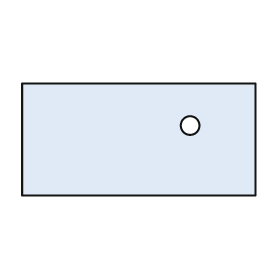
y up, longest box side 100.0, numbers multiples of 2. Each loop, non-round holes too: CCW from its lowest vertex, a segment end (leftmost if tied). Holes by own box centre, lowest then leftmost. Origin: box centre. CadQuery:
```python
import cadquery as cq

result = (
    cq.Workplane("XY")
    .moveTo(-50.0, -24.0)
    .lineTo(50.0, -24.0)
    .lineTo(50.0, 24.0)
    .lineTo(-50.0, 24.0)
    .close()
    .moveTo(22.0, 6.0)
    .circle(4.0)
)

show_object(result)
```